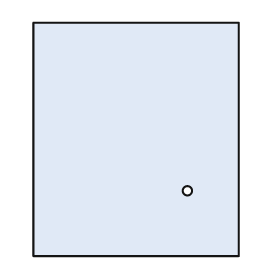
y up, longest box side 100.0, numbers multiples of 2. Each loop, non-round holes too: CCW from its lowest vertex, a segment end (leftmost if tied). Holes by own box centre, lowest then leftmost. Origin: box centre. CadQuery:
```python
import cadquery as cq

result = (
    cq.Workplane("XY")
    .moveTo(-44.0, -50.0)
    .lineTo(44.0, -50.0)
    .lineTo(44.0, 50.0)
    .lineTo(-44.0, 50.0)
    .close()
    .moveTo(22.0, -22.0)
    .circle(2.0)
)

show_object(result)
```